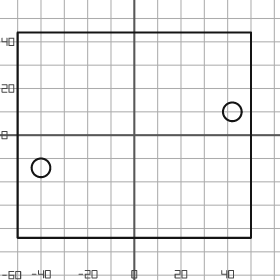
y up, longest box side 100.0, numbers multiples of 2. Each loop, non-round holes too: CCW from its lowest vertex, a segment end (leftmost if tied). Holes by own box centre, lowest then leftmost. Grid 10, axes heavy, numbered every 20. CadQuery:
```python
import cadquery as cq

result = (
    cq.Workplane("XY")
    .moveTo(-50.0, -44.0)
    .lineTo(50.0, -44.0)
    .lineTo(50.0, 44.0)
    .lineTo(-50.0, 44.0)
    .close()
    .moveTo(-40.0, -14.0)
    .circle(4.0)
    .moveTo(42.0, 10.0)
    .circle(4.0)
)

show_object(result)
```